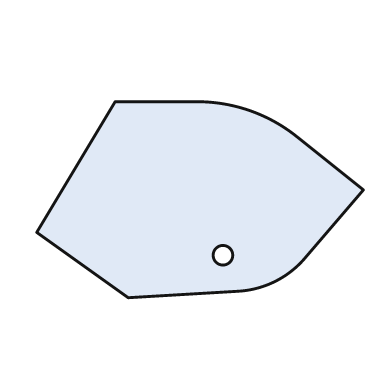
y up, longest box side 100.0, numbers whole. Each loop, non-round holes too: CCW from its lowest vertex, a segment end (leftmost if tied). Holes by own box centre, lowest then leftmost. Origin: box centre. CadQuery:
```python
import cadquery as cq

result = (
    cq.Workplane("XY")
    .moveTo(-22.0, -30.0)
    .lineTo(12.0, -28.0)
    .threePointArc((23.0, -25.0), (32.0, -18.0))
    .lineTo(50.0, 3.0)
    .lineTo(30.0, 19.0)
    .threePointArc((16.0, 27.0), (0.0, 30.0))
    .lineTo(-26.0, 30.0)
    .lineTo(-50.0, -10.0)
    .close()
    .moveTo(7.0, -17.0)
    .circle(3.0)
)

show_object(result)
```